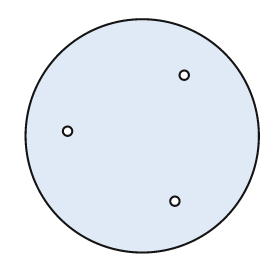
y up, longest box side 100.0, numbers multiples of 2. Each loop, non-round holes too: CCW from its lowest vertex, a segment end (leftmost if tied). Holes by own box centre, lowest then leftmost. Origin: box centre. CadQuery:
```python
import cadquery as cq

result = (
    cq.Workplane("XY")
    .moveTo(0.0, 0.0)
    .circle(50.0)
    .moveTo(14.0, -28.0)
    .circle(2.0)
    .moveTo(-32.0, 2.0)
    .circle(2.0)
    .moveTo(18.0, 26.0)
    .circle(2.0)
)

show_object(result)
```